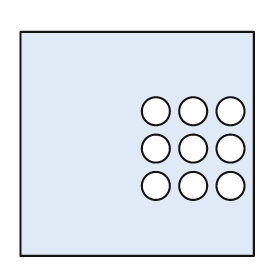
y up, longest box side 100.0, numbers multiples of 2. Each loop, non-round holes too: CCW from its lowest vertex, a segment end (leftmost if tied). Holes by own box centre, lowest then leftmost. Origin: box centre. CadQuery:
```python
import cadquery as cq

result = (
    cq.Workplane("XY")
    .moveTo(-50.0, -48.0)
    .lineTo(50.0, -48.0)
    .lineTo(50.0, 48.0)
    .lineTo(-50.0, 48.0)
    .close()
    .moveTo(8.0, -18.0)
    .circle(6.0)
    .moveTo(24.0, -18.0)
    .circle(6.0)
    .moveTo(40.0, -18.0)
    .circle(6.0)
    .moveTo(8.0, -2.0)
    .circle(6.0)
    .moveTo(24.0, -2.0)
    .circle(6.0)
    .moveTo(40.0, -2.0)
    .circle(6.0)
    .moveTo(8.0, 14.0)
    .circle(6.0)
    .moveTo(24.0, 14.0)
    .circle(6.0)
    .moveTo(40.0, 14.0)
    .circle(6.0)
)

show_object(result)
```